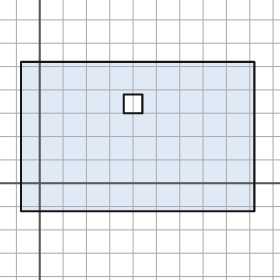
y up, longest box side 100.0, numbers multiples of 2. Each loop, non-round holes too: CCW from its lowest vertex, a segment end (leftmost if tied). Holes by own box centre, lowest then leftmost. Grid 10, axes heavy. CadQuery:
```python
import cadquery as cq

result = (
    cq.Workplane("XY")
    .moveTo(-8.0, -12.0)
    .lineTo(92.0, -12.0)
    .lineTo(92.0, 52.0)
    .lineTo(-8.0, 52.0)
    .close()
    .moveTo(36.0, 30.0)
    .lineTo(44.0, 30.0)
    .lineTo(44.0, 38.0)
    .lineTo(36.0, 38.0)
    .close()
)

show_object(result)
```